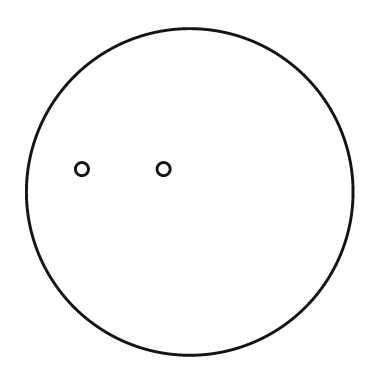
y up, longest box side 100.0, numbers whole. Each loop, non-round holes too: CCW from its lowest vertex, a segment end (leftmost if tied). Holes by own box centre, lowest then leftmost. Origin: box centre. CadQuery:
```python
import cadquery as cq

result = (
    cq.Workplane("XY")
    .moveTo(0.0, 0.0)
    .circle(50.0)
    .moveTo(-33.0, 7.0)
    .circle(2.0)
    .moveTo(-8.0, 7.0)
    .circle(2.0)
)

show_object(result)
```